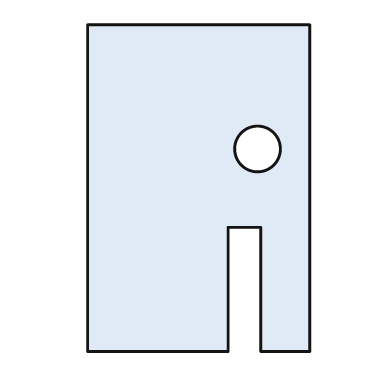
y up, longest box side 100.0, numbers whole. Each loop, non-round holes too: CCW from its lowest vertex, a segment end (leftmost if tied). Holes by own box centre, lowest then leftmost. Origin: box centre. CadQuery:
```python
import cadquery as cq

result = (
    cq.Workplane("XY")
    .moveTo(-34.0, -50.0)
    .lineTo(9.0, -50.0)
    .lineTo(9.0, -12.0)
    .lineTo(19.0, -12.0)
    .lineTo(19.0, -50.0)
    .lineTo(34.0, -50.0)
    .lineTo(34.0, 50.0)
    .lineTo(-34.0, 50.0)
    .close()
    .moveTo(18.0, 12.0)
    .circle(7.0)
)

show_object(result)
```